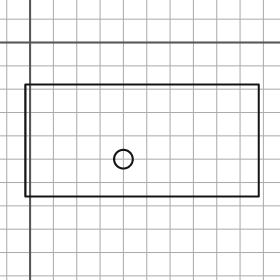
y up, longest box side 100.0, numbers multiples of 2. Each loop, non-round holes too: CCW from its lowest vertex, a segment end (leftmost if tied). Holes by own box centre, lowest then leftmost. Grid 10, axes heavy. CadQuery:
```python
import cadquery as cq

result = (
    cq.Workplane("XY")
    .moveTo(-2.0, -66.0)
    .lineTo(98.0, -66.0)
    .lineTo(98.0, -18.0)
    .lineTo(-2.0, -18.0)
    .close()
    .moveTo(40.0, -50.0)
    .circle(4.0)
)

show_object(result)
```